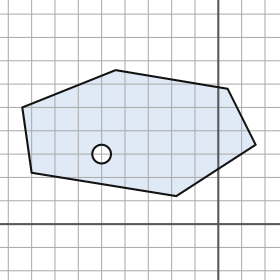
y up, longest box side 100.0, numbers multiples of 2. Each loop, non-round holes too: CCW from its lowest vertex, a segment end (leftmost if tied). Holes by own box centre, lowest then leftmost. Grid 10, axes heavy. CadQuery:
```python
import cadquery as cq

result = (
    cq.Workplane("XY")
    .moveTo(-18.0, 12.0)
    .lineTo(16.0, 34.0)
    .lineTo(4.0, 58.0)
    .lineTo(-44.0, 66.0)
    .lineTo(-84.0, 50.0)
    .lineTo(-80.0, 22.0)
    .close()
    .moveTo(-50.0, 30.0)
    .circle(4.0)
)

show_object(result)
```